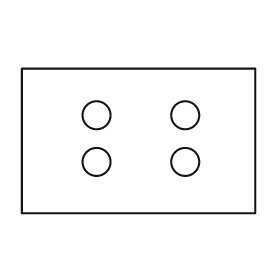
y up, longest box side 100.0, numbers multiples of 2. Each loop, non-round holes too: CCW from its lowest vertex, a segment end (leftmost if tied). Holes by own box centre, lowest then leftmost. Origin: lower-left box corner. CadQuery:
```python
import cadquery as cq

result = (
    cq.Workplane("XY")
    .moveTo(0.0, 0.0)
    .lineTo(100.0, 0.0)
    .lineTo(100.0, 62.0)
    .lineTo(0.0, 62.0)
    .close()
    .moveTo(32.0, 22.0)
    .circle(6.0)
    .moveTo(70.0, 22.0)
    .circle(6.0)
    .moveTo(32.0, 42.0)
    .circle(6.0)
    .moveTo(70.0, 42.0)
    .circle(6.0)
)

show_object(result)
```